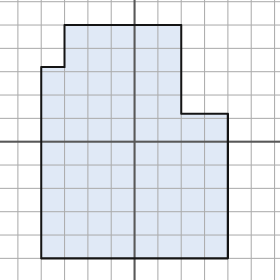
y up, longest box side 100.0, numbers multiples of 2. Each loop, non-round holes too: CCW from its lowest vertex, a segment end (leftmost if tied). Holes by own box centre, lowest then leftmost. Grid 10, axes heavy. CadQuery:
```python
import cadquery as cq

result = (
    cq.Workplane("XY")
    .moveTo(-40.0, -50.0)
    .lineTo(40.0, -50.0)
    .lineTo(40.0, 12.0)
    .lineTo(20.0, 12.0)
    .lineTo(20.0, 50.0)
    .lineTo(-30.0, 50.0)
    .lineTo(-30.0, 32.0)
    .lineTo(-40.0, 32.0)
    .close()
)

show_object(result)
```